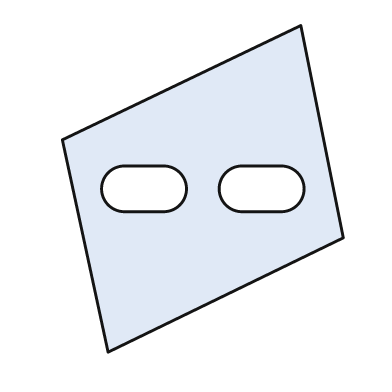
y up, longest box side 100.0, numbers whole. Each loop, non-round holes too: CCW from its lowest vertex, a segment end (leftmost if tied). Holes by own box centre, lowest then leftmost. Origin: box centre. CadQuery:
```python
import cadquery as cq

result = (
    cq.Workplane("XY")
    .moveTo(-29.0, -50.0)
    .lineTo(43.0, -15.0)
    .lineTo(30.0, 50.0)
    .lineTo(-43.0, 15.0)
    .close()
    .moveTo(-24.0, -7.0)
    .lineTo(-12.0, -7.0)
    .threePointArc((-5.0, 0.0), (-12.0, 7.0))
    .lineTo(-24.0, 7.0)
    .threePointArc((-31.0, 0.0), (-24.0, -7.0))
    .close()
    .moveTo(12.0, -7.0)
    .lineTo(24.0, -7.0)
    .threePointArc((31.0, 0.0), (24.0, 7.0))
    .lineTo(12.0, 7.0)
    .threePointArc((5.0, 0.0), (12.0, -7.0))
    .close()
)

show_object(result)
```